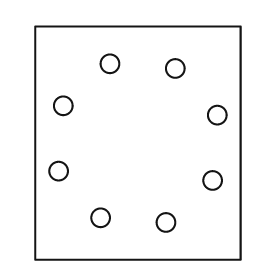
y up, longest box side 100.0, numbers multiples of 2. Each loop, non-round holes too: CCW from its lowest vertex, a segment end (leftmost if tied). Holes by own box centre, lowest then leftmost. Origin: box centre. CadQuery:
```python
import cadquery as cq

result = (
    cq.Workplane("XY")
    .moveTo(-44.0, -50.0)
    .lineTo(44.0, -50.0)
    .lineTo(44.0, 50.0)
    .lineTo(-44.0, 50.0)
    .close()
    .moveTo(12.0, -34.0)
    .circle(4.0)
    .moveTo(-16.0, -32.0)
    .circle(4.0)
    .moveTo(32.0, -16.0)
    .circle(4.0)
    .moveTo(-34.0, -12.0)
    .circle(4.0)
    .moveTo(34.0, 12.0)
    .circle(4.0)
    .moveTo(-32.0, 16.0)
    .circle(4.0)
    .moveTo(16.0, 32.0)
    .circle(4.0)
    .moveTo(-12.0, 34.0)
    .circle(4.0)
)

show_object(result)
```